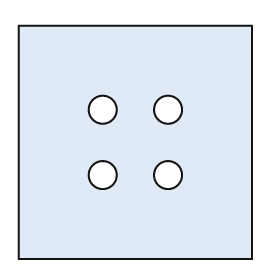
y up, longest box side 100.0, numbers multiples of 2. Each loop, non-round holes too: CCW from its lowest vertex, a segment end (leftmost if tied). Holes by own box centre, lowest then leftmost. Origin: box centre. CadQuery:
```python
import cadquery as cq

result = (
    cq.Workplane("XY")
    .moveTo(-50.0, -50.0)
    .lineTo(50.0, -50.0)
    .lineTo(50.0, 50.0)
    .lineTo(-50.0, 50.0)
    .close()
    .moveTo(-14.0, -14.0)
    .circle(6.0)
    .moveTo(14.0, -14.0)
    .circle(6.0)
    .moveTo(-14.0, 14.0)
    .circle(6.0)
    .moveTo(14.0, 14.0)
    .circle(6.0)
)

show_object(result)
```